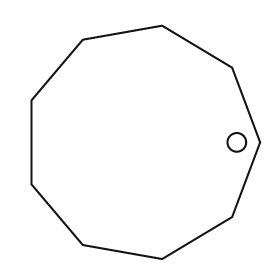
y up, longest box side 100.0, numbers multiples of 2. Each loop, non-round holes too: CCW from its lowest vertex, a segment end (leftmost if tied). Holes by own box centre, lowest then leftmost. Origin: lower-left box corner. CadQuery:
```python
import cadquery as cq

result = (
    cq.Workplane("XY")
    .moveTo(56.0, 0.0)
    .lineTo(86.0, 18.0)
    .lineTo(98.0, 50.0)
    .lineTo(86.0, 82.0)
    .lineTo(56.0, 100.0)
    .lineTo(22.0, 94.0)
    .lineTo(0.0, 68.0)
    .lineTo(0.0, 32.0)
    .lineTo(22.0, 6.0)
    .close()
    .moveTo(88.0, 50.0)
    .circle(4.0)
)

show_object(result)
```